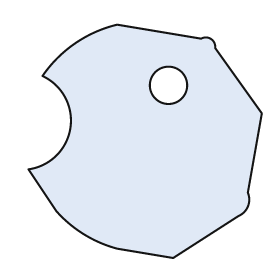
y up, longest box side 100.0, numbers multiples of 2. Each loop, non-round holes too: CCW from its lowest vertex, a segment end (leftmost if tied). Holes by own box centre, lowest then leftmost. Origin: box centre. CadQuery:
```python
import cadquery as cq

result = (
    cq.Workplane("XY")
    .moveTo(12.0, -50.0)
    .lineTo(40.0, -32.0)
    .threePointArc((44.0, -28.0), (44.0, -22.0))
    .lineTo(50.0, 12.0)
    .lineTo(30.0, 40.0)
    .threePointArc((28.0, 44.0), (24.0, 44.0))
    .lineTo(-12.0, 50.0)
    .threePointArc((-30.0, 42.0), (-44.0, 28.0))
    .threePointArc((-32.0, 6.0), (-50.0, -12.0))
    .lineTo(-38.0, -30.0)
    .threePointArc((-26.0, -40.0), (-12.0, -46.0))
    .close()
    .moveTo(10.0, 24.0)
    .circle(8.0)
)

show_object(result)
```